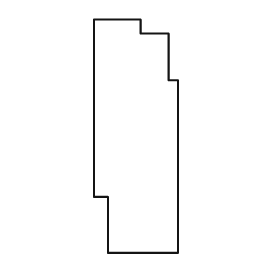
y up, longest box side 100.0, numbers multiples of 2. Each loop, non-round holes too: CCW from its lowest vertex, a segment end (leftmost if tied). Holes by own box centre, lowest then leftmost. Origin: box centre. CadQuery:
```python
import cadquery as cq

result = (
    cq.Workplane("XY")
    .moveTo(-12.0, -50.0)
    .lineTo(18.0, -50.0)
    .lineTo(18.0, 24.0)
    .lineTo(14.0, 24.0)
    .lineTo(14.0, 44.0)
    .lineTo(2.0, 44.0)
    .lineTo(2.0, 50.0)
    .lineTo(-18.0, 50.0)
    .lineTo(-18.0, -26.0)
    .lineTo(-12.0, -26.0)
    .close()
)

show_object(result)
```